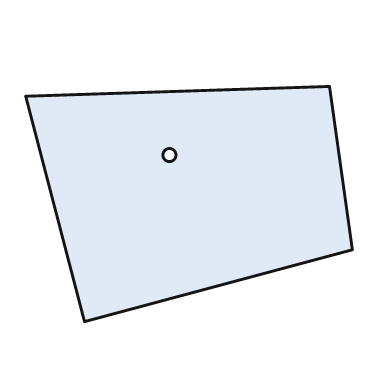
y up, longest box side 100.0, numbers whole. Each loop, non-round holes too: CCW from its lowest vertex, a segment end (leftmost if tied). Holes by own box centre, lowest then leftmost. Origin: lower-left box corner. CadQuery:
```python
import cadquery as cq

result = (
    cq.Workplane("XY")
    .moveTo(18.0, 0.0)
    .lineTo(100.0, 22.0)
    .lineTo(93.0, 72.0)
    .lineTo(0.0, 69.0)
    .close()
    .moveTo(44.0, 51.0)
    .circle(2.0)
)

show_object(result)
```